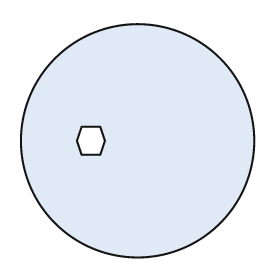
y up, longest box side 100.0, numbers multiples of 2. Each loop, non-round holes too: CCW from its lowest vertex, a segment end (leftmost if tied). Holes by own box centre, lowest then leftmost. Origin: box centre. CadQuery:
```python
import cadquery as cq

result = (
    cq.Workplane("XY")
    .moveTo(0.0, 0.0)
    .circle(50.0)
    .moveTo(-24.0, -6.0)
    .lineTo(-16.0, -6.0)
    .lineTo(-14.0, 0.0)
    .lineTo(-16.0, 6.0)
    .lineTo(-24.0, 6.0)
    .lineTo(-26.0, 0.0)
    .close()
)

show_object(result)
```